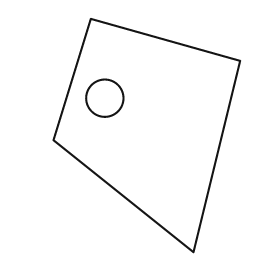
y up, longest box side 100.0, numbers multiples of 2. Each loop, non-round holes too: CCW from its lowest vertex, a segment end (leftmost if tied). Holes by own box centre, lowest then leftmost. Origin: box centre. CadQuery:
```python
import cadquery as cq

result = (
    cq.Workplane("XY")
    .moveTo(20.0, -50.0)
    .lineTo(40.0, 32.0)
    .lineTo(-24.0, 50.0)
    .lineTo(-40.0, -2.0)
    .close()
    .moveTo(-18.0, 16.0)
    .circle(8.0)
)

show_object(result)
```